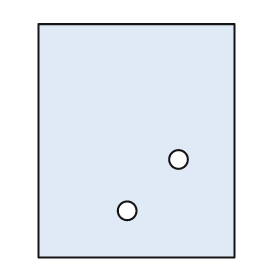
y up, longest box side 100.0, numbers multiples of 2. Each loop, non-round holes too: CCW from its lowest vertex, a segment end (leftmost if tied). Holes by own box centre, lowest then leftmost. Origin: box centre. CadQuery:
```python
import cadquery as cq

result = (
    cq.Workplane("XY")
    .moveTo(-42.0, -50.0)
    .lineTo(42.0, -50.0)
    .lineTo(42.0, 50.0)
    .lineTo(-42.0, 50.0)
    .close()
    .moveTo(-4.0, -30.0)
    .circle(4.0)
    .moveTo(18.0, -8.0)
    .circle(4.0)
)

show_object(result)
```